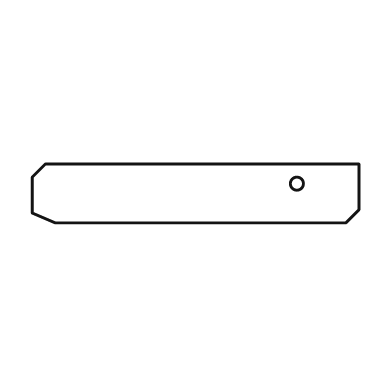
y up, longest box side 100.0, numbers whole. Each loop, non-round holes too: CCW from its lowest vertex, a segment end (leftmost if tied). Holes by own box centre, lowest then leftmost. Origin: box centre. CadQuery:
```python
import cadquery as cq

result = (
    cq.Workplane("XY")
    .moveTo(-43.0, -9.0)
    .lineTo(46.0, -9.0)
    .lineTo(50.0, -5.0)
    .lineTo(50.0, 9.0)
    .lineTo(-46.0, 9.0)
    .lineTo(-50.0, 5.0)
    .lineTo(-50.0, -6.0)
    .close()
    .moveTo(31.0, 3.0)
    .circle(2.0)
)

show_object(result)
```